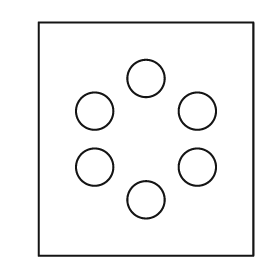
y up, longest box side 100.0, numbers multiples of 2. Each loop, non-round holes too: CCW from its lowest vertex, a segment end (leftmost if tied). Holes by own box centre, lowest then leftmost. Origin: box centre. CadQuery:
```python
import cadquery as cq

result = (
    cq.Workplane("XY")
    .moveTo(-46.0, -50.0)
    .lineTo(46.0, -50.0)
    .lineTo(46.0, 50.0)
    .lineTo(-46.0, 50.0)
    .close()
    .moveTo(0.0, -26.0)
    .circle(8.0)
    .moveTo(-22.0, -12.0)
    .circle(8.0)
    .moveTo(22.0, -12.0)
    .circle(8.0)
    .moveTo(-22.0, 12.0)
    .circle(8.0)
    .moveTo(22.0, 12.0)
    .circle(8.0)
    .moveTo(0.0, 26.0)
    .circle(8.0)
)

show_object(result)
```